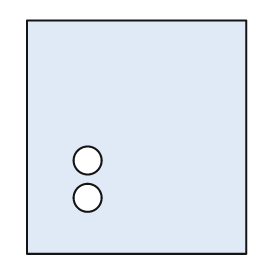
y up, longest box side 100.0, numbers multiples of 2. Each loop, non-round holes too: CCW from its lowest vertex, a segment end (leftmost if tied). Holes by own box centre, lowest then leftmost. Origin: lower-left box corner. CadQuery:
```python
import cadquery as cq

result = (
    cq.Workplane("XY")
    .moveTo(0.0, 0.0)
    .lineTo(94.0, 0.0)
    .lineTo(94.0, 100.0)
    .lineTo(0.0, 100.0)
    .close()
    .moveTo(26.0, 24.0)
    .circle(6.0)
    .moveTo(26.0, 40.0)
    .circle(6.0)
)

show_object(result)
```